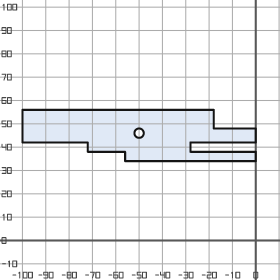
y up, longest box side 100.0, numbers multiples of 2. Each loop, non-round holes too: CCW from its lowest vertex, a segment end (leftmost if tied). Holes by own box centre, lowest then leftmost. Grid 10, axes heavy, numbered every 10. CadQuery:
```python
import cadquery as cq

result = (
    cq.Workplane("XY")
    .moveTo(-56.0, 34.0)
    .lineTo(0.0, 34.0)
    .lineTo(0.0, 38.0)
    .lineTo(-28.0, 38.0)
    .lineTo(-28.0, 42.0)
    .lineTo(0.0, 42.0)
    .lineTo(0.0, 48.0)
    .lineTo(-18.0, 48.0)
    .lineTo(-18.0, 56.0)
    .lineTo(-100.0, 56.0)
    .lineTo(-100.0, 42.0)
    .lineTo(-72.0, 42.0)
    .lineTo(-72.0, 38.0)
    .lineTo(-56.0, 38.0)
    .close()
    .moveTo(-50.0, 46.0)
    .circle(2.0)
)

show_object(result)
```